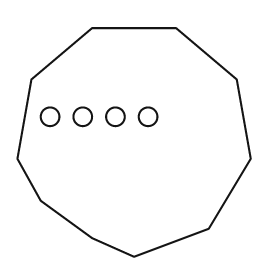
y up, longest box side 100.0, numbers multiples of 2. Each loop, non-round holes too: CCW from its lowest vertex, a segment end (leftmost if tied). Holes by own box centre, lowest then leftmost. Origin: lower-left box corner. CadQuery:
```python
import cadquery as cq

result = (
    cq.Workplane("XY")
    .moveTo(50.0, 0.0)
    .lineTo(82.0, 12.0)
    .lineTo(100.0, 42.0)
    .lineTo(94.0, 76.0)
    .lineTo(68.0, 98.0)
    .lineTo(32.0, 98.0)
    .lineTo(6.0, 76.0)
    .lineTo(0.0, 42.0)
    .lineTo(10.0, 24.0)
    .lineTo(32.0, 8.0)
    .close()
    .moveTo(14.0, 60.0)
    .circle(4.0)
    .moveTo(28.0, 60.0)
    .circle(4.0)
    .moveTo(42.0, 60.0)
    .circle(4.0)
    .moveTo(56.0, 60.0)
    .circle(4.0)
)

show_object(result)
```